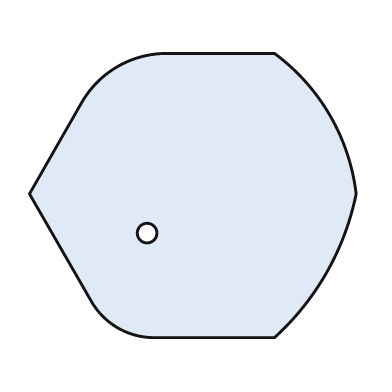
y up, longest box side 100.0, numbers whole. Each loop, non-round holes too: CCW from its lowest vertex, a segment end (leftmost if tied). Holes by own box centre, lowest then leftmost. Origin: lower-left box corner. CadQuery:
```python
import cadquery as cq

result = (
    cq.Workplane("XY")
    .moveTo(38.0, 0.0)
    .lineTo(75.0, 0.0)
    .threePointArc((91.0, 20.0), (100.0, 44.0))
    .threePointArc((92.0, 68.0), (75.0, 87.0))
    .lineTo(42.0, 87.0)
    .threePointArc((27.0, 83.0), (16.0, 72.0))
    .lineTo(0.0, 44.0)
    .lineTo(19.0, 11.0)
    .threePointArc((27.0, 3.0), (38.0, 0.0))
    .close()
    .moveTo(36.0, 32.0)
    .circle(3.0)
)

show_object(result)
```